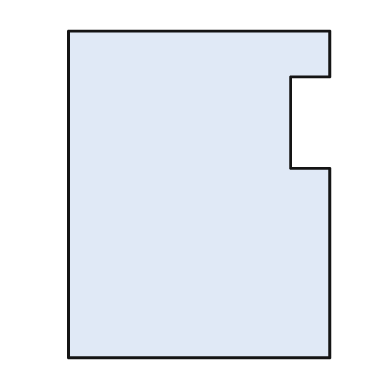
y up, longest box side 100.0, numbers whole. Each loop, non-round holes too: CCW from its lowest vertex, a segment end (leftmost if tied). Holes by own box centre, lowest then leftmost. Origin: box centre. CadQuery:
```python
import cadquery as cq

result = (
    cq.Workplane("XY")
    .moveTo(-40.0, -50.0)
    .lineTo(40.0, -50.0)
    .lineTo(40.0, 8.0)
    .lineTo(28.0, 8.0)
    .lineTo(28.0, 36.0)
    .lineTo(40.0, 36.0)
    .lineTo(40.0, 50.0)
    .lineTo(-40.0, 50.0)
    .close()
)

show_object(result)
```